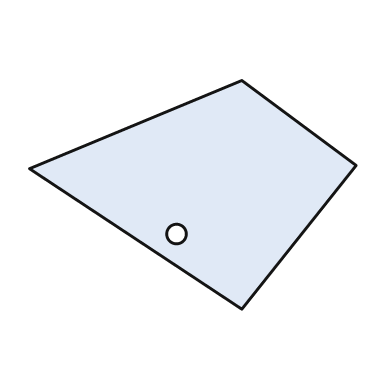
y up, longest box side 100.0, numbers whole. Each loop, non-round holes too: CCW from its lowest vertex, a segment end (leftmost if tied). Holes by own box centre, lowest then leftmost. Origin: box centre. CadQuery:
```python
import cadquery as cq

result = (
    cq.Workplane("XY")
    .moveTo(15.0, -35.0)
    .lineTo(50.0, 9.0)
    .lineTo(15.0, 35.0)
    .lineTo(-50.0, 8.0)
    .close()
    .moveTo(-5.0, -12.0)
    .circle(3.0)
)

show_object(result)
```